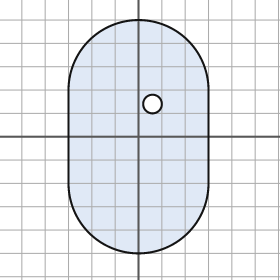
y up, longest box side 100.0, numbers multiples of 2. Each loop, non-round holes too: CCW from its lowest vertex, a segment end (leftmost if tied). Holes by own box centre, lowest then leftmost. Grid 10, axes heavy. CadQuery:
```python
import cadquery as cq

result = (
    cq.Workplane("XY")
    .moveTo(-30.0, -20.0)
    .threePointArc((0.0, -50.0), (30.0, -20.0))
    .lineTo(30.0, 20.0)
    .threePointArc((0.0, 50.0), (-30.0, 20.0))
    .close()
    .moveTo(6.0, 14.0)
    .circle(4.0)
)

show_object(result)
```